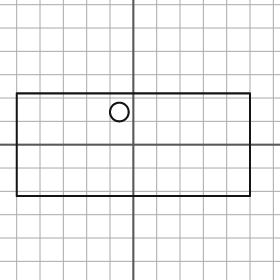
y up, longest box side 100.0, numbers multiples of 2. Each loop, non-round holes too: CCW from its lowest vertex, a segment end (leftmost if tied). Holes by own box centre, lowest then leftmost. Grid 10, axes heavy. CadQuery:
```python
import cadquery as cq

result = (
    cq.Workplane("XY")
    .moveTo(-50.0, -22.0)
    .lineTo(50.0, -22.0)
    .lineTo(50.0, 22.0)
    .lineTo(-50.0, 22.0)
    .close()
    .moveTo(-6.0, 14.0)
    .circle(4.0)
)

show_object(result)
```